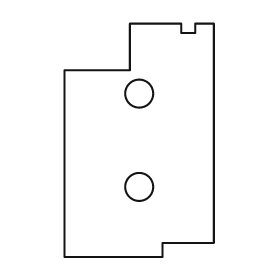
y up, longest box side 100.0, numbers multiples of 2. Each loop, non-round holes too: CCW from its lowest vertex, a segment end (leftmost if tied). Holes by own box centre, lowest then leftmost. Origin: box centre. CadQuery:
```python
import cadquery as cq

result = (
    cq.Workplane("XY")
    .moveTo(-32.0, -50.0)
    .lineTo(10.0, -50.0)
    .lineTo(10.0, -44.0)
    .lineTo(32.0, -44.0)
    .lineTo(32.0, 50.0)
    .lineTo(24.0, 50.0)
    .lineTo(24.0, 46.0)
    .lineTo(18.0, 46.0)
    .lineTo(18.0, 50.0)
    .lineTo(-4.0, 50.0)
    .lineTo(-4.0, 30.0)
    .lineTo(-32.0, 30.0)
    .close()
    .moveTo(0.0, -20.0)
    .circle(6.0)
    .moveTo(0.0, 20.0)
    .circle(6.0)
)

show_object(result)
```